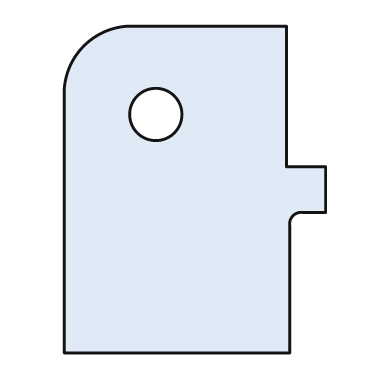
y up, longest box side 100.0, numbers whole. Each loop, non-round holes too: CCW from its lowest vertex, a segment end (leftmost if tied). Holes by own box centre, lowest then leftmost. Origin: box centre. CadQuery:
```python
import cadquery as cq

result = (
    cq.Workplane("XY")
    .moveTo(-40.0, -50.0)
    .lineTo(29.0, -50.0)
    .lineTo(29.0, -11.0)
    .threePointArc((30.0, -8.0), (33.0, -7.0))
    .lineTo(40.0, -7.0)
    .lineTo(40.0, 7.0)
    .lineTo(28.0, 7.0)
    .lineTo(28.0, 50.0)
    .lineTo(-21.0, 50.0)
    .threePointArc((-34.0, 44.0), (-40.0, 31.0))
    .close()
    .moveTo(-12.0, 23.0)
    .circle(8.0)
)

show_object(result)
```